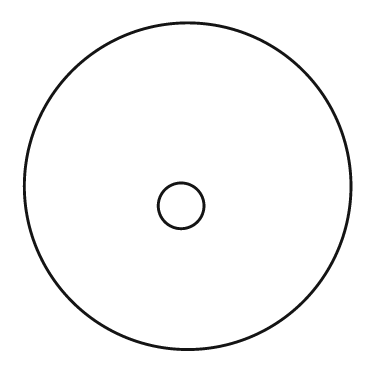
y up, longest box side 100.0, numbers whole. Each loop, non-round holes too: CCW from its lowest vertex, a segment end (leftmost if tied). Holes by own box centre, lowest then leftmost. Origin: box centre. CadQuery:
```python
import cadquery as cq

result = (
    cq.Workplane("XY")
    .moveTo(0.0, 0.0)
    .circle(50.0)
    .moveTo(-2.0, -6.0)
    .circle(7.0)
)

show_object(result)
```